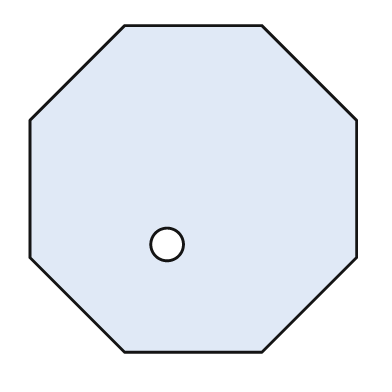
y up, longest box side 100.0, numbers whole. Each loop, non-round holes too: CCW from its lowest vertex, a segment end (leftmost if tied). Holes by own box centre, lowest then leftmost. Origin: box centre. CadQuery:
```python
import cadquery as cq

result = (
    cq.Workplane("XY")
    .moveTo(-21.0, -50.0)
    .lineTo(21.0, -50.0)
    .lineTo(50.0, -21.0)
    .lineTo(50.0, 21.0)
    .lineTo(21.0, 50.0)
    .lineTo(-21.0, 50.0)
    .lineTo(-50.0, 21.0)
    .lineTo(-50.0, -21.0)
    .close()
    .moveTo(-8.0, -17.0)
    .circle(5.0)
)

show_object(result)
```